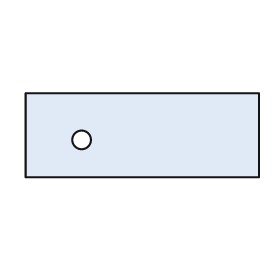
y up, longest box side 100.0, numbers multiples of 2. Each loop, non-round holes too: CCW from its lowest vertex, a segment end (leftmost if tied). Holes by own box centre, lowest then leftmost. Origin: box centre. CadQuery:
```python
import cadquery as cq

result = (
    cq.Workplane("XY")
    .moveTo(-50.0, -18.0)
    .lineTo(50.0, -18.0)
    .lineTo(50.0, 18.0)
    .lineTo(-50.0, 18.0)
    .close()
    .moveTo(-26.0, -2.0)
    .circle(4.0)
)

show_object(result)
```